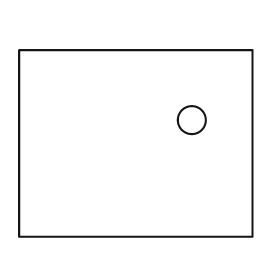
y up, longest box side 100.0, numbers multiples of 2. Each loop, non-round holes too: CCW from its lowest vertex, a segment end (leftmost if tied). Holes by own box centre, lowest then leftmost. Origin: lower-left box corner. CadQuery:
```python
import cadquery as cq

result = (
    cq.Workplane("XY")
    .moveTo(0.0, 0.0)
    .lineTo(100.0, 0.0)
    .lineTo(100.0, 80.0)
    .lineTo(0.0, 80.0)
    .close()
    .moveTo(74.0, 50.0)
    .circle(6.0)
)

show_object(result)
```